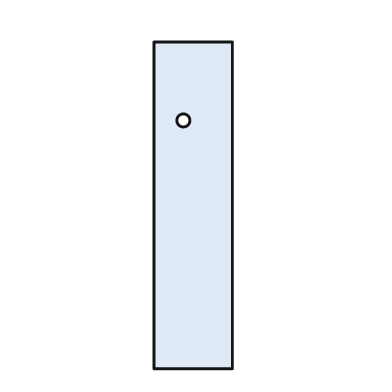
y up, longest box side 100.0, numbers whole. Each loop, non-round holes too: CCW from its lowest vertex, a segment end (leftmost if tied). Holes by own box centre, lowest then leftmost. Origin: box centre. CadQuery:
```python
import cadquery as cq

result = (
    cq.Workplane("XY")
    .moveTo(-12.0, -50.0)
    .lineTo(12.0, -50.0)
    .lineTo(12.0, 50.0)
    .lineTo(-12.0, 50.0)
    .close()
    .moveTo(-3.0, 26.0)
    .circle(2.0)
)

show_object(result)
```